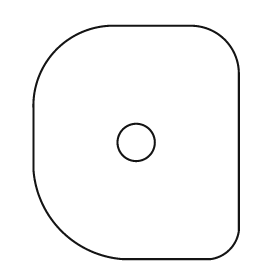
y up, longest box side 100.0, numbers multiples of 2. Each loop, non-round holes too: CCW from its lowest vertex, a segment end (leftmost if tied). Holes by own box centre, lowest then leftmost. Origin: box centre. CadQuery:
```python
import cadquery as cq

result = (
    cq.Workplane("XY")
    .moveTo(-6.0, -50.0)
    .lineTo(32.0, -50.0)
    .threePointArc((40.0, -46.0), (44.0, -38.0))
    .lineTo(44.0, 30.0)
    .threePointArc((38.0, 44.0), (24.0, 50.0))
    .lineTo(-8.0, 50.0)
    .threePointArc((-34.0, 40.0), (-44.0, 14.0))
    .lineTo(-44.0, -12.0)
    .threePointArc((-32.0, -38.0), (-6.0, -50.0))
    .close()
    .moveTo(0.0, 0.0)
    .circle(8.0)
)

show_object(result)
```